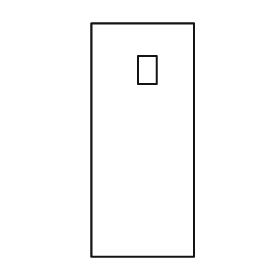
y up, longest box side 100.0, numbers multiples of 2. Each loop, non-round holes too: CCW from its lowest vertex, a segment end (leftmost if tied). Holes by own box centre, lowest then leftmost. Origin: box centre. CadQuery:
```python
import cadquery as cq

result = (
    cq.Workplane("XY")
    .moveTo(-22.0, -50.0)
    .lineTo(22.0, -50.0)
    .lineTo(22.0, 50.0)
    .lineTo(-22.0, 50.0)
    .close()
    .moveTo(-2.0, 24.0)
    .lineTo(6.0, 24.0)
    .lineTo(6.0, 36.0)
    .lineTo(-2.0, 36.0)
    .close()
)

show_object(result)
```